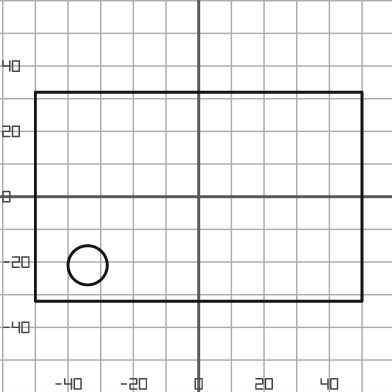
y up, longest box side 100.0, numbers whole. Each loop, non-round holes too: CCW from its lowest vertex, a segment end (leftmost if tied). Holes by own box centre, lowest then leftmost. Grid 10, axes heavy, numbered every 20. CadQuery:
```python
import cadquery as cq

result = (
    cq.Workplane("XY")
    .moveTo(-50.0, -32.0)
    .lineTo(50.0, -32.0)
    .lineTo(50.0, 32.0)
    .lineTo(-50.0, 32.0)
    .close()
    .moveTo(-34.0, -21.0)
    .circle(6.0)
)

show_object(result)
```